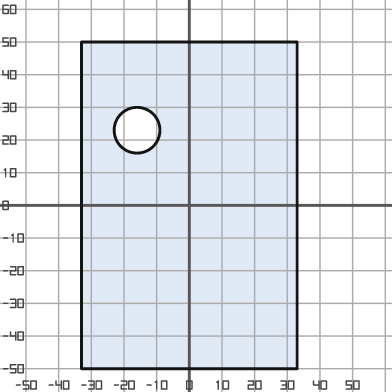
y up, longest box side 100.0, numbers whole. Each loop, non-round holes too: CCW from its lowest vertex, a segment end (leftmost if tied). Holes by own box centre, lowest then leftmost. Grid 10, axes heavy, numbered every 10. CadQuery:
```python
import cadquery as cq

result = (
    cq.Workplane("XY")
    .moveTo(-33.0, -50.0)
    .lineTo(33.0, -50.0)
    .lineTo(33.0, 50.0)
    .lineTo(-33.0, 50.0)
    .close()
    .moveTo(-16.0, 23.0)
    .circle(7.0)
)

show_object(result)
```